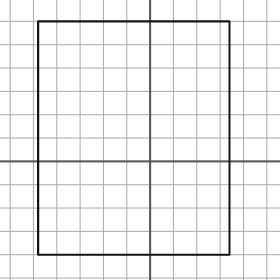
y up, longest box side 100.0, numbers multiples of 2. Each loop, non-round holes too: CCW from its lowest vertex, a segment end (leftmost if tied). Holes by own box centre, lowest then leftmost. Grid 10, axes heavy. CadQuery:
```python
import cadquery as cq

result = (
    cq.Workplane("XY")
    .moveTo(-48.0, -40.0)
    .lineTo(34.0, -40.0)
    .lineTo(34.0, 60.0)
    .lineTo(-48.0, 60.0)
    .close()
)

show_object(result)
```